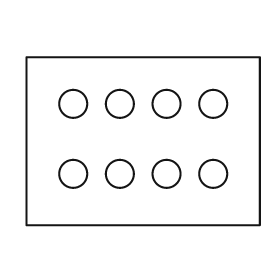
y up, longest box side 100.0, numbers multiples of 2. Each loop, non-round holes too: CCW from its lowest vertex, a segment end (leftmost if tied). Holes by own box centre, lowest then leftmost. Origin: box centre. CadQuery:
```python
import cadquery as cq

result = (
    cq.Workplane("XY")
    .moveTo(-50.0, -36.0)
    .lineTo(50.0, -36.0)
    .lineTo(50.0, 36.0)
    .lineTo(-50.0, 36.0)
    .close()
    .moveTo(-30.0, -14.0)
    .circle(6.0)
    .moveTo(-10.0, -14.0)
    .circle(6.0)
    .moveTo(10.0, -14.0)
    .circle(6.0)
    .moveTo(30.0, -14.0)
    .circle(6.0)
    .moveTo(-30.0, 16.0)
    .circle(6.0)
    .moveTo(-10.0, 16.0)
    .circle(6.0)
    .moveTo(10.0, 16.0)
    .circle(6.0)
    .moveTo(30.0, 16.0)
    .circle(6.0)
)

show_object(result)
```